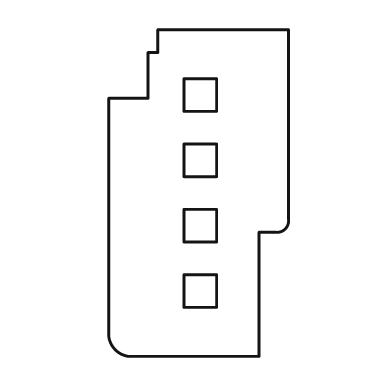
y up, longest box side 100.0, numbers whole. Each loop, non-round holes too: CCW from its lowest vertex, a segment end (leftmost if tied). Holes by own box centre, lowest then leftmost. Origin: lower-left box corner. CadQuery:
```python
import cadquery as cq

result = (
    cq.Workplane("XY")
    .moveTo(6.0, 0.0)
    .lineTo(46.0, 0.0)
    .lineTo(46.0, 38.0)
    .lineTo(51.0, 38.0)
    .threePointArc((54.0, 39.0), (55.0, 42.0))
    .lineTo(55.0, 100.0)
    .lineTo(15.0, 100.0)
    .lineTo(15.0, 93.0)
    .lineTo(12.0, 93.0)
    .lineTo(12.0, 79.0)
    .lineTo(0.0, 79.0)
    .lineTo(0.0, 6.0)
    .threePointArc((2.0, 2.0), (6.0, 0.0))
    .close()
    .moveTo(23.0, 15.0)
    .lineTo(33.0, 15.0)
    .lineTo(33.0, 25.0)
    .lineTo(23.0, 25.0)
    .close()
    .moveTo(23.0, 35.0)
    .lineTo(33.0, 35.0)
    .lineTo(33.0, 45.0)
    .lineTo(23.0, 45.0)
    .close()
    .moveTo(23.0, 55.0)
    .lineTo(33.0, 55.0)
    .lineTo(33.0, 65.0)
    .lineTo(23.0, 65.0)
    .close()
    .moveTo(23.0, 75.0)
    .lineTo(33.0, 75.0)
    .lineTo(33.0, 85.0)
    .lineTo(23.0, 85.0)
    .close()
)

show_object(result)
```